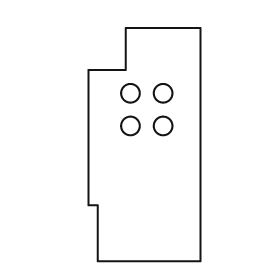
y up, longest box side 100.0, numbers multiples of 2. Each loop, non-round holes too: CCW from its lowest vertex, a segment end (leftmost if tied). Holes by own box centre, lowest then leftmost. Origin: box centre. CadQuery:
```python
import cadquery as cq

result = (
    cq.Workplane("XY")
    .moveTo(-20.0, -50.0)
    .lineTo(24.0, -50.0)
    .lineTo(24.0, 50.0)
    .lineTo(-8.0, 50.0)
    .lineTo(-8.0, 32.0)
    .lineTo(-24.0, 32.0)
    .lineTo(-24.0, -26.0)
    .lineTo(-20.0, -26.0)
    .close()
    .moveTo(-6.0, 8.0)
    .circle(4.0)
    .moveTo(8.0, 8.0)
    .circle(4.0)
    .moveTo(-6.0, 22.0)
    .circle(4.0)
    .moveTo(8.0, 22.0)
    .circle(4.0)
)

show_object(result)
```